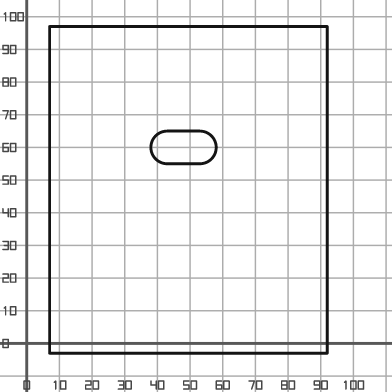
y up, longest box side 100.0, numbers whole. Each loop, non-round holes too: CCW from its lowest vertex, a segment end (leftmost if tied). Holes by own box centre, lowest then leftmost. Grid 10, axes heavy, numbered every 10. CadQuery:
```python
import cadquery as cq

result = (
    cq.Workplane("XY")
    .moveTo(7.0, -3.0)
    .lineTo(92.0, -3.0)
    .lineTo(92.0, 97.0)
    .lineTo(7.0, 97.0)
    .close()
    .moveTo(43.0, 55.0)
    .lineTo(53.0, 55.0)
    .threePointArc((58.0, 60.0), (53.0, 65.0))
    .lineTo(43.0, 65.0)
    .threePointArc((38.0, 60.0), (43.0, 55.0))
    .close()
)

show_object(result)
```